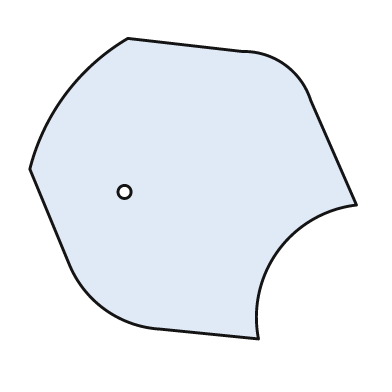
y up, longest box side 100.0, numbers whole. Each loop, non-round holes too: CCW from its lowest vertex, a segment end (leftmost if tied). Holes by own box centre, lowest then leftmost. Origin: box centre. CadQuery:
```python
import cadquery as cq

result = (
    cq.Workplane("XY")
    .moveTo(20.0, -46.0)
    .threePointArc((26.0, -19.0), (50.0, -5.0))
    .lineTo(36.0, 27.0)
    .threePointArc((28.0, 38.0), (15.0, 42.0))
    .lineTo(-20.0, 46.0)
    .threePointArc((-39.0, 29.0), (-50.0, 6.0))
    .lineTo(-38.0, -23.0)
    .threePointArc((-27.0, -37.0), (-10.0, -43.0))
    .close()
    .moveTo(-21.0, -1.0)
    .circle(2.0)
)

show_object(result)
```